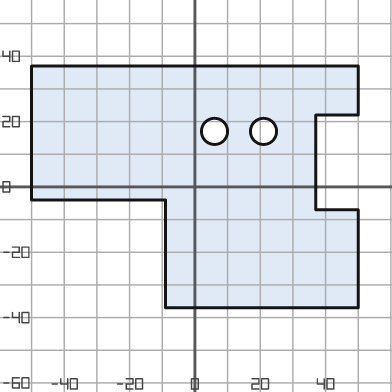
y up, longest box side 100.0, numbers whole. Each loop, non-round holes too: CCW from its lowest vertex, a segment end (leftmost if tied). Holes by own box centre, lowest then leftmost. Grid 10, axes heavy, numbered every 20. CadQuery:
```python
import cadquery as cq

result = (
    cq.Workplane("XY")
    .moveTo(-9.0, -37.0)
    .lineTo(50.0, -37.0)
    .lineTo(50.0, -7.0)
    .lineTo(37.0, -7.0)
    .lineTo(37.0, 22.0)
    .lineTo(50.0, 22.0)
    .lineTo(50.0, 37.0)
    .lineTo(-50.0, 37.0)
    .lineTo(-50.0, -4.0)
    .lineTo(-9.0, -4.0)
    .close()
    .moveTo(6.0, 17.0)
    .circle(4.0)
    .moveTo(21.0, 17.0)
    .circle(4.0)
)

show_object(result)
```